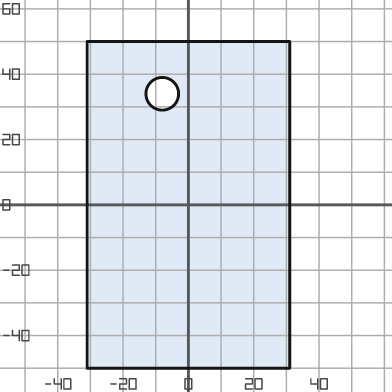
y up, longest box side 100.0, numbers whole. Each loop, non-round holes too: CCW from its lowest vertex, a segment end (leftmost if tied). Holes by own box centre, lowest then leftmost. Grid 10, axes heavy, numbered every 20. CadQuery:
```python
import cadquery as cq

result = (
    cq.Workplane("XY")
    .moveTo(-31.0, -50.0)
    .lineTo(31.0, -50.0)
    .lineTo(31.0, 50.0)
    .lineTo(-31.0, 50.0)
    .close()
    .moveTo(-8.0, 34.0)
    .circle(5.0)
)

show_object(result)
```